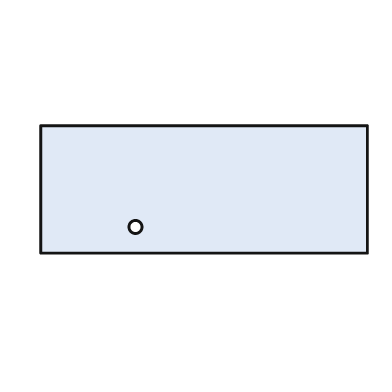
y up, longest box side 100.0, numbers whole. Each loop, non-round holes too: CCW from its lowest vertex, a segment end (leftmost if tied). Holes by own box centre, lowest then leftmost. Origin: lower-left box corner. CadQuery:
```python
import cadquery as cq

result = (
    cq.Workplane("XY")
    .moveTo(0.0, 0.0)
    .lineTo(100.0, 0.0)
    .lineTo(100.0, 39.0)
    .lineTo(0.0, 39.0)
    .close()
    .moveTo(29.0, 8.0)
    .circle(2.0)
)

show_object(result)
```